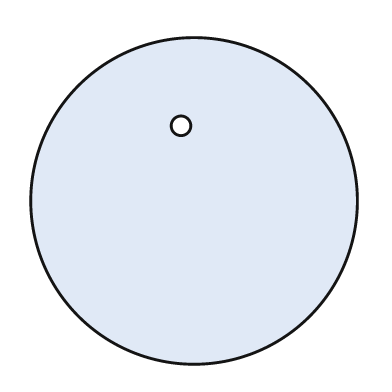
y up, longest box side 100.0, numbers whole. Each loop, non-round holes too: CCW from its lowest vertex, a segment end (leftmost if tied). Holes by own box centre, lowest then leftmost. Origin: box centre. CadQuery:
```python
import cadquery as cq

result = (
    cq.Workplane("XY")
    .moveTo(0.0, 0.0)
    .circle(50.0)
    .moveTo(-4.0, 23.0)
    .circle(3.0)
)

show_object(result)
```